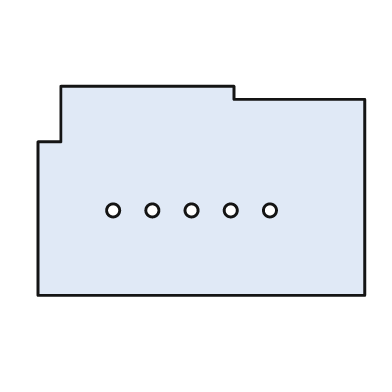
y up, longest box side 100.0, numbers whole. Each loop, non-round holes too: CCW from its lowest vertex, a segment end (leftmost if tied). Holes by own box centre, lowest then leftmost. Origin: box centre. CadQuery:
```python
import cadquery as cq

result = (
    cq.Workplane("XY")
    .moveTo(-50.0, -32.0)
    .lineTo(50.0, -32.0)
    .lineTo(50.0, 28.0)
    .lineTo(10.0, 28.0)
    .lineTo(10.0, 32.0)
    .lineTo(-43.0, 32.0)
    .lineTo(-43.0, 15.0)
    .lineTo(-50.0, 15.0)
    .close()
    .moveTo(-27.0, -6.0)
    .circle(2.0)
    .moveTo(-15.0, -6.0)
    .circle(2.0)
    .moveTo(-3.0, -6.0)
    .circle(2.0)
    .moveTo(9.0, -6.0)
    .circle(2.0)
    .moveTo(21.0, -6.0)
    .circle(2.0)
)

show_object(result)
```